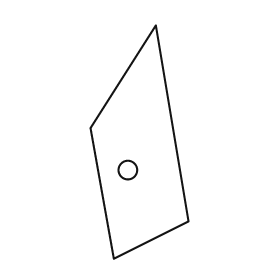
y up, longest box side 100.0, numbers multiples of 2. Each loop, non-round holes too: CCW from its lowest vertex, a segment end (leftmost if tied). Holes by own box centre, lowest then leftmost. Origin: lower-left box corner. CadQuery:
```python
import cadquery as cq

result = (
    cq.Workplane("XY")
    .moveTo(10.0, 0.0)
    .lineTo(42.0, 16.0)
    .lineTo(28.0, 100.0)
    .lineTo(0.0, 56.0)
    .close()
    .moveTo(16.0, 38.0)
    .circle(4.0)
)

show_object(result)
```